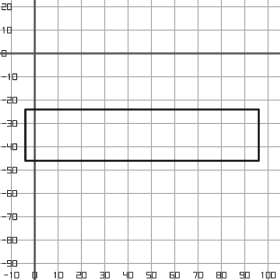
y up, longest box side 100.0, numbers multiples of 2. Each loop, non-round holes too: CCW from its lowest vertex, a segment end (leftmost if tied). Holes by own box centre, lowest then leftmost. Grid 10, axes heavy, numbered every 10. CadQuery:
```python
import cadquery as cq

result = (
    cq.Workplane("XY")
    .moveTo(-4.0, -46.0)
    .lineTo(96.0, -46.0)
    .lineTo(96.0, -24.0)
    .lineTo(-4.0, -24.0)
    .close()
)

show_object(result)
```